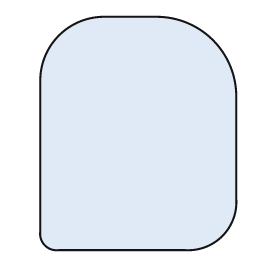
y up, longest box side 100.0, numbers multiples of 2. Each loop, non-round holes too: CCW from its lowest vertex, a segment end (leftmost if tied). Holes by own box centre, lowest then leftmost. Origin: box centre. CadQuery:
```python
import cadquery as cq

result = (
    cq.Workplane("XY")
    .moveTo(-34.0, -50.0)
    .lineTo(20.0, -50.0)
    .threePointArc((36.0, -44.0), (42.0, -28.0))
    .lineTo(42.0, 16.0)
    .threePointArc((32.0, 40.0), (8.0, 50.0))
    .lineTo(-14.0, 50.0)
    .threePointArc((-34.0, 42.0), (-42.0, 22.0))
    .lineTo(-42.0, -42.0)
    .threePointArc((-40.0, -48.0), (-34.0, -50.0))
    .close()
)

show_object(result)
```